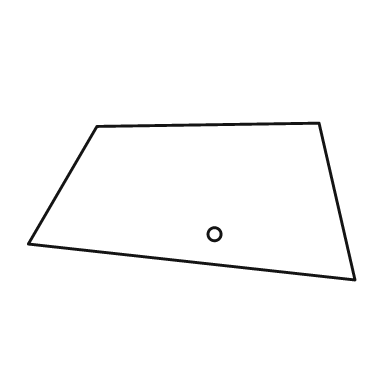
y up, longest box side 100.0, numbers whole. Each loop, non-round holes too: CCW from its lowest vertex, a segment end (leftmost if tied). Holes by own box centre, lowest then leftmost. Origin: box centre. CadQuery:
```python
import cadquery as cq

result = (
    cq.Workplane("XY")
    .moveTo(50.0, -24.0)
    .lineTo(39.0, 24.0)
    .lineTo(-29.0, 23.0)
    .lineTo(-50.0, -13.0)
    .close()
    .moveTo(7.0, -10.0)
    .circle(2.0)
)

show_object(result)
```